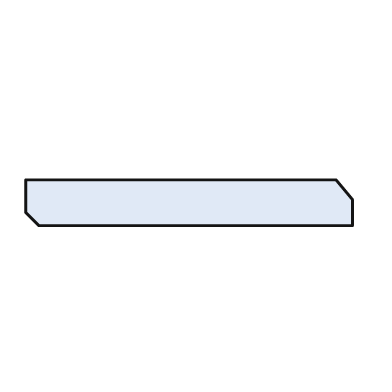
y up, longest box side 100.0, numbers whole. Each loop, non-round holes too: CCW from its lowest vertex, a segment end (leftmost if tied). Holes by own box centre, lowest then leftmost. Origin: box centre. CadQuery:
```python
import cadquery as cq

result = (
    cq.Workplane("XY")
    .moveTo(-46.0, -7.0)
    .lineTo(50.0, -7.0)
    .lineTo(50.0, 1.0)
    .lineTo(45.0, 7.0)
    .lineTo(-50.0, 7.0)
    .lineTo(-50.0, -3.0)
    .close()
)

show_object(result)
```